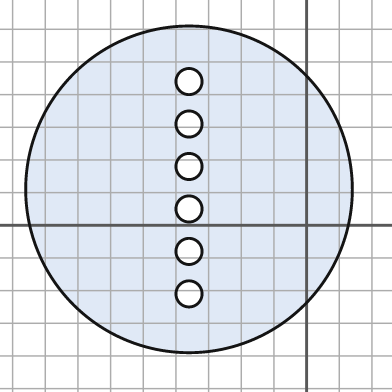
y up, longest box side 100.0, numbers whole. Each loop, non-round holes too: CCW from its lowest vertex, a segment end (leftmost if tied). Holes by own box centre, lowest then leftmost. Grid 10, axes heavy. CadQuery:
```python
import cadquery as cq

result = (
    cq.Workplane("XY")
    .moveTo(-36.0, 11.0)
    .circle(50.0)
    .moveTo(-36.0, -21.0)
    .circle(4.0)
    .moveTo(-36.0, -8.0)
    .circle(4.0)
    .moveTo(-36.0, 5.0)
    .circle(4.0)
    .moveTo(-36.0, 18.0)
    .circle(4.0)
    .moveTo(-36.0, 31.0)
    .circle(4.0)
    .moveTo(-36.0, 44.0)
    .circle(4.0)
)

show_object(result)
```